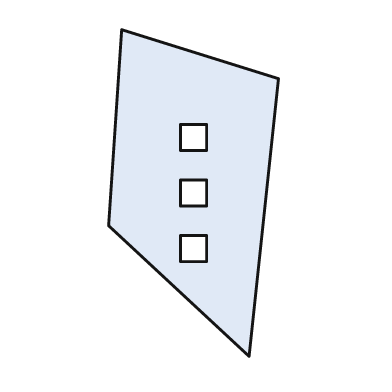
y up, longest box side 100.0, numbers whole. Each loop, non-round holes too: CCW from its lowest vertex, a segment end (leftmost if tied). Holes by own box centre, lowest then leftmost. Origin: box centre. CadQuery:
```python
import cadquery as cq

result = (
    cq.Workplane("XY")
    .moveTo(17.0, -50.0)
    .lineTo(26.0, 35.0)
    .lineTo(-22.0, 50.0)
    .lineTo(-26.0, -10.0)
    .close()
    .moveTo(-4.0, -21.0)
    .lineTo(4.0, -21.0)
    .lineTo(4.0, -13.0)
    .lineTo(-4.0, -13.0)
    .close()
    .moveTo(-4.0, -4.0)
    .lineTo(4.0, -4.0)
    .lineTo(4.0, 4.0)
    .lineTo(-4.0, 4.0)
    .close()
    .moveTo(-4.0, 13.0)
    .lineTo(4.0, 13.0)
    .lineTo(4.0, 21.0)
    .lineTo(-4.0, 21.0)
    .close()
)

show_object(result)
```